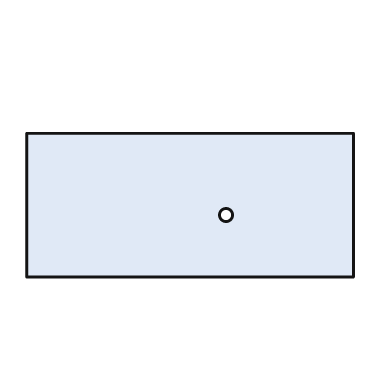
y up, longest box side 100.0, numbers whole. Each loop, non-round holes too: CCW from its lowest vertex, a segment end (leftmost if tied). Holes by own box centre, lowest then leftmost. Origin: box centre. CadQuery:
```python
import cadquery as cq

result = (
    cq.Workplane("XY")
    .moveTo(-50.0, -22.0)
    .lineTo(50.0, -22.0)
    .lineTo(50.0, 22.0)
    .lineTo(-50.0, 22.0)
    .close()
    .moveTo(11.0, -3.0)
    .circle(2.0)
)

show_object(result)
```